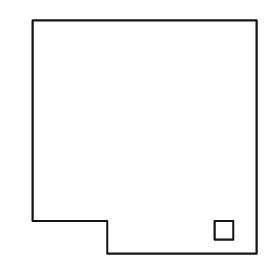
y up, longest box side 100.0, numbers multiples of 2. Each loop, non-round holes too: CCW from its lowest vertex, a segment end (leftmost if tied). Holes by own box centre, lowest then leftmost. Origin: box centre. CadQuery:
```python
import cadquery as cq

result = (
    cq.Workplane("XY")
    .moveTo(-16.0, -50.0)
    .lineTo(48.0, -50.0)
    .lineTo(48.0, 50.0)
    .lineTo(-48.0, 50.0)
    .lineTo(-48.0, -36.0)
    .lineTo(-16.0, -36.0)
    .close()
    .moveTo(30.0, -44.0)
    .lineTo(38.0, -44.0)
    .lineTo(38.0, -36.0)
    .lineTo(30.0, -36.0)
    .close()
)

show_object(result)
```